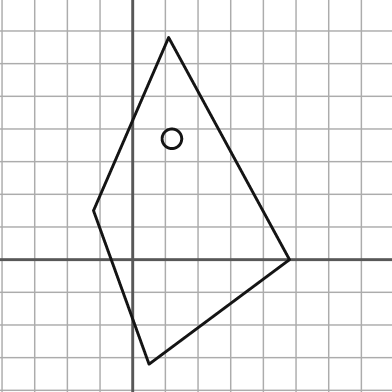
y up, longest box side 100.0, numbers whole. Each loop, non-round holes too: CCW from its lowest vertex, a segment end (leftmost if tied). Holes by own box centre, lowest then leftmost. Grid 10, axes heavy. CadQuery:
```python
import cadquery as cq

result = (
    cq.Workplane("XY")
    .moveTo(5.0, -32.0)
    .lineTo(48.0, 0.0)
    .lineTo(11.0, 68.0)
    .lineTo(-12.0, 15.0)
    .close()
    .moveTo(12.0, 37.0)
    .circle(3.0)
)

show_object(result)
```